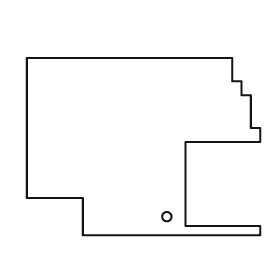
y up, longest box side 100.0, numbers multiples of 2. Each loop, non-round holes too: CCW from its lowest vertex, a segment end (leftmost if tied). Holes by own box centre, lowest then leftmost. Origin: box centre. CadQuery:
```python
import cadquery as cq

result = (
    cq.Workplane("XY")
    .moveTo(-26.0, -38.0)
    .lineTo(50.0, -38.0)
    .lineTo(50.0, -34.0)
    .lineTo(18.0, -34.0)
    .lineTo(18.0, 2.0)
    .lineTo(50.0, 2.0)
    .lineTo(50.0, 8.0)
    .lineTo(46.0, 8.0)
    .lineTo(46.0, 22.0)
    .lineTo(42.0, 22.0)
    .lineTo(42.0, 28.0)
    .lineTo(38.0, 28.0)
    .lineTo(38.0, 38.0)
    .lineTo(-50.0, 38.0)
    .lineTo(-50.0, -22.0)
    .lineTo(-26.0, -22.0)
    .close()
    .moveTo(10.0, -30.0)
    .circle(2.0)
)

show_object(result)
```